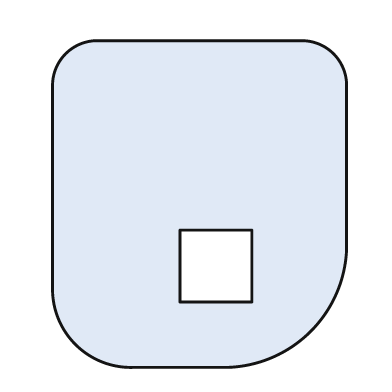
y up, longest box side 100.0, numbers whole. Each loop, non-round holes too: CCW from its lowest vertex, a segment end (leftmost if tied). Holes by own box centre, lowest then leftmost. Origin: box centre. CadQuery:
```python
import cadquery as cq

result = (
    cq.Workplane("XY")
    .moveTo(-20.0, -50.0)
    .lineTo(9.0, -50.0)
    .threePointArc((34.0, -39.0), (45.0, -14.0))
    .lineTo(45.0, 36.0)
    .threePointArc((41.0, 46.0), (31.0, 50.0))
    .lineTo(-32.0, 50.0)
    .threePointArc((-41.0, 46.0), (-45.0, 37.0))
    .lineTo(-45.0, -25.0)
    .threePointArc((-38.0, -43.0), (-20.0, -50.0))
    .close()
    .moveTo(-6.0, -30.0)
    .lineTo(16.0, -30.0)
    .lineTo(16.0, -8.0)
    .lineTo(-6.0, -8.0)
    .close()
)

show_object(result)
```